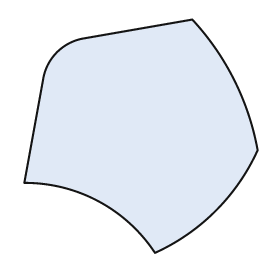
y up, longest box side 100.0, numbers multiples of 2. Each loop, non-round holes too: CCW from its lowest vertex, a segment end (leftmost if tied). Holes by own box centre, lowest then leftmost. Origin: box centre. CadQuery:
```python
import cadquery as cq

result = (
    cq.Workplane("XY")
    .moveTo(6.0, -50.0)
    .threePointArc((32.0, -32.0), (50.0, -6.0))
    .threePointArc((40.0, 24.0), (22.0, 50.0))
    .lineTo(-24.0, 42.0)
    .threePointArc((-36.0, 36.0), (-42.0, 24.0))
    .lineTo(-50.0, -20.0)
    .threePointArc((-18.0, -28.0), (6.0, -50.0))
    .close()
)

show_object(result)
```